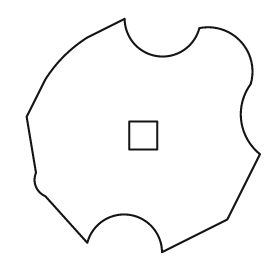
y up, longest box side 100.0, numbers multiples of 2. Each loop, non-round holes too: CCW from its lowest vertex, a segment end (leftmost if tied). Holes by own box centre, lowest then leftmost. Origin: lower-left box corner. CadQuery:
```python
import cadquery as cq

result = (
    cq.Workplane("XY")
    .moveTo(58.0, 0.0)
    .lineTo(86.0, 14.0)
    .lineTo(100.0, 42.0)
    .threePointArc((92.0, 56.0), (96.0, 72.0))
    .threePointArc((92.0, 90.0), (74.0, 96.0))
    .threePointArc((56.0, 84.0), (42.0, 100.0))
    .lineTo(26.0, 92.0)
    .threePointArc((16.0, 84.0), (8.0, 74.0))
    .lineTo(0.0, 58.0)
    .lineTo(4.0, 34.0)
    .threePointArc((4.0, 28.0), (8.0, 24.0))
    .lineTo(26.0, 4.0)
    .threePointArc((44.0, 16.0), (58.0, 0.0))
    .close()
    .moveTo(44.0, 44.0)
    .lineTo(56.0, 44.0)
    .lineTo(56.0, 56.0)
    .lineTo(44.0, 56.0)
    .close()
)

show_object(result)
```